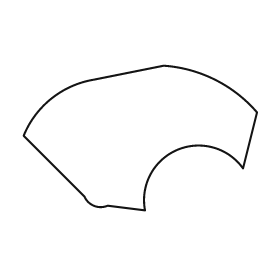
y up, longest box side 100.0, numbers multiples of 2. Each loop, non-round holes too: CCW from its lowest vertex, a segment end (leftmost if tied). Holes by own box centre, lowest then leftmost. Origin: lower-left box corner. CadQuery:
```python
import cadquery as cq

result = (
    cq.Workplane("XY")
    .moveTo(52.0, 0.0)
    .threePointArc((66.0, 26.0), (94.0, 18.0))
    .lineTo(100.0, 42.0)
    .threePointArc((82.0, 56.0), (60.0, 62.0))
    .lineTo(30.0, 56.0)
    .threePointArc((12.0, 48.0), (0.0, 32.0))
    .lineTo(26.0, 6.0)
    .threePointArc((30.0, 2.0), (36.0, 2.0))
    .close()
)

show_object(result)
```